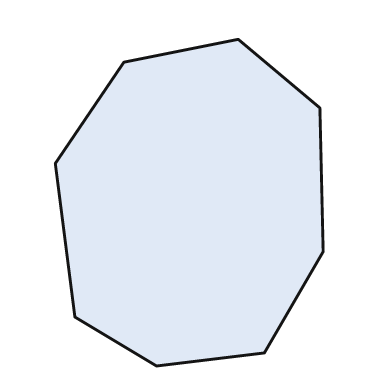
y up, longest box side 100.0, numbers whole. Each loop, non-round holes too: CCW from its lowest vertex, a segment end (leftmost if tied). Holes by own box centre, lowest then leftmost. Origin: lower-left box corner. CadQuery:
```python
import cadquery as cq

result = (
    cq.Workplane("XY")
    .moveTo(31.0, 0.0)
    .lineTo(64.0, 4.0)
    .lineTo(82.0, 35.0)
    .lineTo(81.0, 79.0)
    .lineTo(56.0, 100.0)
    .lineTo(21.0, 93.0)
    .lineTo(0.0, 62.0)
    .lineTo(6.0, 15.0)
    .close()
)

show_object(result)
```